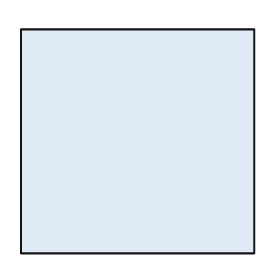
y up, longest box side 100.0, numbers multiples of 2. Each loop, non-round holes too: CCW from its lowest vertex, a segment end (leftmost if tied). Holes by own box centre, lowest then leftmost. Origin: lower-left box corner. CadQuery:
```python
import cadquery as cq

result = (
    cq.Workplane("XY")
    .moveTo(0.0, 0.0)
    .lineTo(100.0, 0.0)
    .lineTo(100.0, 96.0)
    .lineTo(0.0, 96.0)
    .close()
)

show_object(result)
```